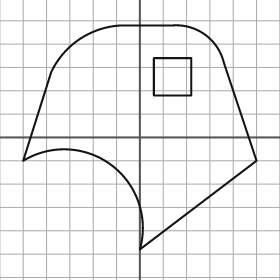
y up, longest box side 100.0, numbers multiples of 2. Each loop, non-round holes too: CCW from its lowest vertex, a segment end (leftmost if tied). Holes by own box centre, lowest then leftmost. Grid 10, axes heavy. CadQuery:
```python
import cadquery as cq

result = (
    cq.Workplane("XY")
    .moveTo(0.0, -48.0)
    .lineTo(50.0, -10.0)
    .lineTo(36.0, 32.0)
    .threePointArc((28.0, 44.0), (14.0, 48.0))
    .lineTo(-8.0, 48.0)
    .threePointArc((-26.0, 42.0), (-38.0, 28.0))
    .lineTo(-50.0, -10.0)
    .threePointArc((-12.0, -12.0), (0.0, -48.0))
    .close()
    .moveTo(6.0, 18.0)
    .lineTo(22.0, 18.0)
    .lineTo(22.0, 34.0)
    .lineTo(6.0, 34.0)
    .close()
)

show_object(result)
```